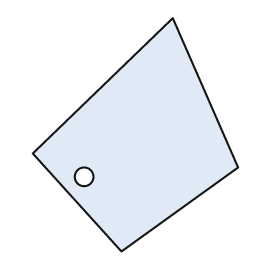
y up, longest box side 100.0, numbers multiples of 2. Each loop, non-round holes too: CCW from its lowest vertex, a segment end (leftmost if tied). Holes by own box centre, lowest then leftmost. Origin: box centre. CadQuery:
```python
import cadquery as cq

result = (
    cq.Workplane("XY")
    .moveTo(-6.0, -50.0)
    .lineTo(44.0, -14.0)
    .lineTo(16.0, 50.0)
    .lineTo(-44.0, -8.0)
    .close()
    .moveTo(-22.0, -18.0)
    .circle(4.0)
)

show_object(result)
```